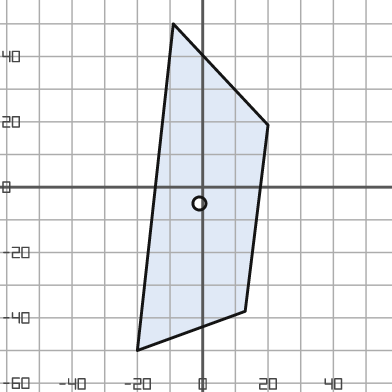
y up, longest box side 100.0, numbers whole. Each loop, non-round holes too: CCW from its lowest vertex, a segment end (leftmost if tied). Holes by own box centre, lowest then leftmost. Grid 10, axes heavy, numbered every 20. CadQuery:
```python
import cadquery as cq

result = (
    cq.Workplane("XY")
    .moveTo(-20.0, -50.0)
    .lineTo(13.0, -38.0)
    .lineTo(20.0, 19.0)
    .lineTo(-9.0, 50.0)
    .close()
    .moveTo(-1.0, -5.0)
    .circle(2.0)
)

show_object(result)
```